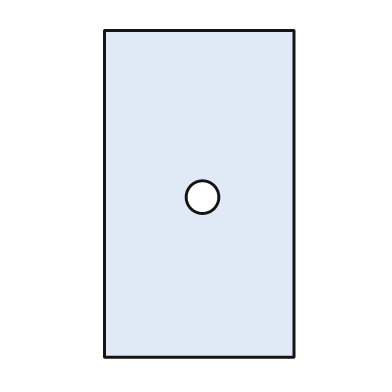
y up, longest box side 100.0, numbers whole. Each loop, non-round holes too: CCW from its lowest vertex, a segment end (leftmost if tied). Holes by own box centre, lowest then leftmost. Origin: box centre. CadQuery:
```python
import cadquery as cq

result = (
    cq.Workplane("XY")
    .moveTo(-29.0, -50.0)
    .lineTo(29.0, -50.0)
    .lineTo(29.0, 50.0)
    .lineTo(-29.0, 50.0)
    .close()
    .moveTo(1.0, -1.0)
    .circle(5.0)
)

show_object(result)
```